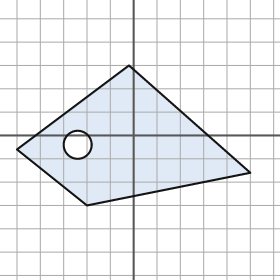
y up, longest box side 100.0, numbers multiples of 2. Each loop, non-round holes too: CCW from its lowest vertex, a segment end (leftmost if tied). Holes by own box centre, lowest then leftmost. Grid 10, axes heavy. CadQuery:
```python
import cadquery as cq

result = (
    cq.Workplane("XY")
    .moveTo(-20.0, -30.0)
    .lineTo(50.0, -16.0)
    .lineTo(-2.0, 30.0)
    .lineTo(-50.0, -6.0)
    .close()
    .moveTo(-24.0, -4.0)
    .circle(6.0)
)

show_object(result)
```